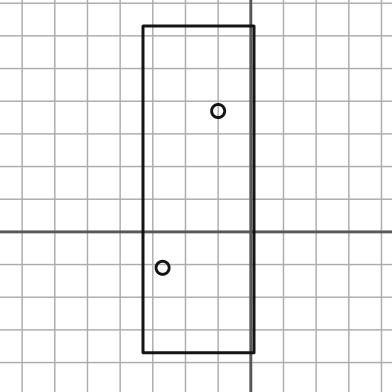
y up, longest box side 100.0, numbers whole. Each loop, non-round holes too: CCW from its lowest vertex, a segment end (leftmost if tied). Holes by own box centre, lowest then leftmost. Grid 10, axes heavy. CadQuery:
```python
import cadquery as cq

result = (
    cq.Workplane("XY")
    .moveTo(-33.0, -37.0)
    .lineTo(1.0, -37.0)
    .lineTo(1.0, 63.0)
    .lineTo(-33.0, 63.0)
    .close()
    .moveTo(-27.0, -11.0)
    .circle(2.0)
    .moveTo(-10.0, 37.0)
    .circle(2.0)
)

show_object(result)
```